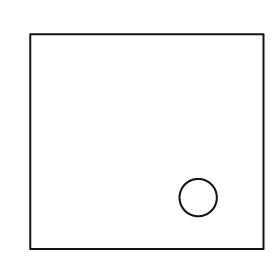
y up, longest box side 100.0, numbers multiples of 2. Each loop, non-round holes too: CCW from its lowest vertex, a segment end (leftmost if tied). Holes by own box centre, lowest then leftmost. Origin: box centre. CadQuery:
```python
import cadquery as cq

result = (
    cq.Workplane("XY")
    .moveTo(-50.0, -46.0)
    .lineTo(50.0, -46.0)
    .lineTo(50.0, 46.0)
    .lineTo(-50.0, 46.0)
    .close()
    .moveTo(22.0, -24.0)
    .circle(8.0)
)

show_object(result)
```